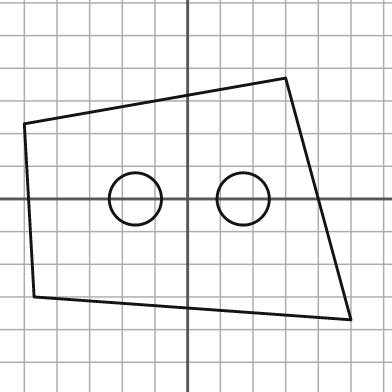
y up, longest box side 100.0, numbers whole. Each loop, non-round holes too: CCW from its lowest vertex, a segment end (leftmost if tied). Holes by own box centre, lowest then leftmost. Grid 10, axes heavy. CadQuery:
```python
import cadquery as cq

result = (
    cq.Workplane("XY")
    .moveTo(50.0, -37.0)
    .lineTo(30.0, 37.0)
    .lineTo(-50.0, 23.0)
    .lineTo(-47.0, -30.0)
    .close()
    .moveTo(-16.0, 0.0)
    .circle(8.0)
    .moveTo(17.0, 0.0)
    .circle(8.0)
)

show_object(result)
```